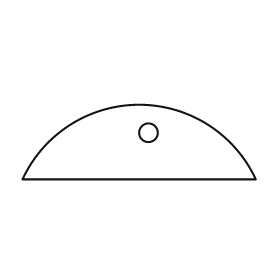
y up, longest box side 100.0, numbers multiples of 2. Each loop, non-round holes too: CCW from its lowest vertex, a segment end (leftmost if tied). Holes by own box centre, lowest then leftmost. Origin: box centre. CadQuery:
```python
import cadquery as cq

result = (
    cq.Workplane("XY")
    .moveTo(-50.0, -16.0)
    .lineTo(50.0, -16.0)
    .threePointArc((0.0, 16.0), (-50.0, -16.0))
    .close()
    .moveTo(4.0, 4.0)
    .circle(4.0)
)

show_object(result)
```